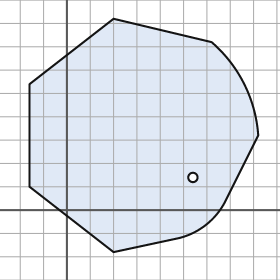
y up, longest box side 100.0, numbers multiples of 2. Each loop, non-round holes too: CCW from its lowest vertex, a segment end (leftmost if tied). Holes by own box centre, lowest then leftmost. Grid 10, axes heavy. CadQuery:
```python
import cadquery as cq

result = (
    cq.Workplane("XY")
    .moveTo(20.0, -18.0)
    .lineTo(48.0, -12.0)
    .threePointArc((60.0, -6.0), (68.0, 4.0))
    .lineTo(82.0, 32.0)
    .threePointArc((76.0, 54.0), (62.0, 72.0))
    .lineTo(20.0, 82.0)
    .lineTo(-16.0, 54.0)
    .lineTo(-16.0, 10.0)
    .close()
    .moveTo(54.0, 14.0)
    .circle(2.0)
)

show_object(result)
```